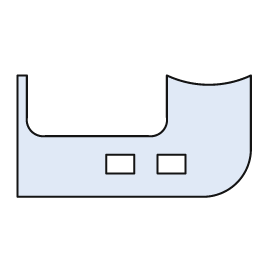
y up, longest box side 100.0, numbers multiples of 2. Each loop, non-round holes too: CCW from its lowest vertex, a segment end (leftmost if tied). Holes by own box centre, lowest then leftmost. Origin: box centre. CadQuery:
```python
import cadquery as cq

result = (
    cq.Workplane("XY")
    .moveTo(-50.0, -26.0)
    .lineTo(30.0, -26.0)
    .threePointArc((44.0, -20.0), (50.0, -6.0))
    .lineTo(50.0, 26.0)
    .threePointArc((32.0, 22.0), (14.0, 26.0))
    .lineTo(14.0, 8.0)
    .threePointArc((12.0, 2.0), (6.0, 0.0))
    .lineTo(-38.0, 0.0)
    .threePointArc((-44.0, 2.0), (-46.0, 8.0))
    .lineTo(-46.0, 26.0)
    .lineTo(-50.0, 26.0)
    .close()
    .moveTo(-12.0, -16.0)
    .lineTo(0.0, -16.0)
    .lineTo(0.0, -8.0)
    .lineTo(-12.0, -8.0)
    .close()
    .moveTo(10.0, -16.0)
    .lineTo(22.0, -16.0)
    .lineTo(22.0, -8.0)
    .lineTo(10.0, -8.0)
    .close()
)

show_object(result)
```